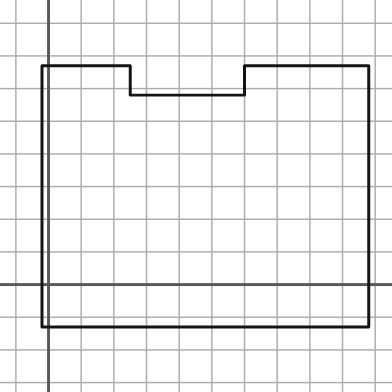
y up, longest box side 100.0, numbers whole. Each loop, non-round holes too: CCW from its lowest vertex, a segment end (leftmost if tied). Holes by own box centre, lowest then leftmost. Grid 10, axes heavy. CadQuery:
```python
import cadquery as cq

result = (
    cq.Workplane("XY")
    .moveTo(-2.0, -13.0)
    .lineTo(98.0, -13.0)
    .lineTo(98.0, 67.0)
    .lineTo(60.0, 67.0)
    .lineTo(60.0, 58.0)
    .lineTo(25.0, 58.0)
    .lineTo(25.0, 67.0)
    .lineTo(-2.0, 67.0)
    .close()
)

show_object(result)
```